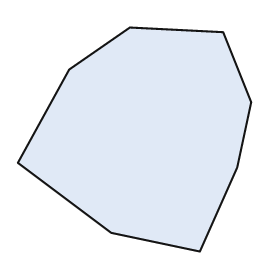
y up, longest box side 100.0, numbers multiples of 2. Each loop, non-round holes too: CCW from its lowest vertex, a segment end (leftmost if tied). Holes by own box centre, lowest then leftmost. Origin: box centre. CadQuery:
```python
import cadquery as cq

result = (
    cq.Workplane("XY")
    .moveTo(28.0, -48.0)
    .lineTo(44.0, -12.0)
    .lineTo(50.0, 16.0)
    .lineTo(38.0, 46.0)
    .lineTo(-2.0, 48.0)
    .lineTo(-28.0, 30.0)
    .lineTo(-50.0, -10.0)
    .lineTo(-10.0, -40.0)
    .close()
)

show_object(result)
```